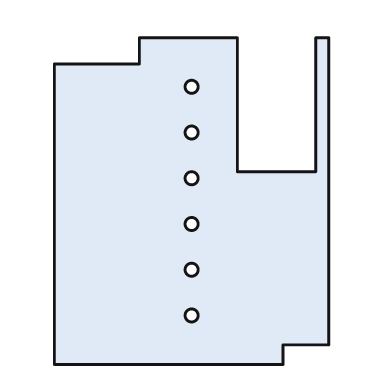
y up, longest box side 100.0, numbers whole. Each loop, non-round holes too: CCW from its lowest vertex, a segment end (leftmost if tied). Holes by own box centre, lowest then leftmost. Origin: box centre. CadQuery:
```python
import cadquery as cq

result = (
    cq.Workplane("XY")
    .moveTo(-42.0, -50.0)
    .lineTo(28.0, -50.0)
    .lineTo(28.0, -44.0)
    .lineTo(42.0, -44.0)
    .lineTo(42.0, 50.0)
    .lineTo(38.0, 50.0)
    .lineTo(38.0, 9.0)
    .lineTo(14.0, 9.0)
    .lineTo(14.0, 50.0)
    .lineTo(-16.0, 50.0)
    .lineTo(-16.0, 42.0)
    .lineTo(-42.0, 42.0)
    .close()
    .moveTo(0.0, -35.0)
    .circle(2.0)
    .moveTo(0.0, -21.0)
    .circle(2.0)
    .moveTo(0.0, -7.0)
    .circle(2.0)
    .moveTo(0.0, 7.0)
    .circle(2.0)
    .moveTo(0.0, 21.0)
    .circle(2.0)
    .moveTo(0.0, 35.0)
    .circle(2.0)
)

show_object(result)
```